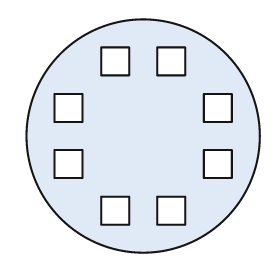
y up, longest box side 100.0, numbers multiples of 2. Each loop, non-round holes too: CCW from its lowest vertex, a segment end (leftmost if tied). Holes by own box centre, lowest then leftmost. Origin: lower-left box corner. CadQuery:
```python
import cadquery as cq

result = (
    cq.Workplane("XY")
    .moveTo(50.0, 50.0)
    .circle(50.0)
    .moveTo(32.0, 12.0)
    .lineTo(44.0, 12.0)
    .lineTo(44.0, 24.0)
    .lineTo(32.0, 24.0)
    .close()
    .moveTo(56.0, 12.0)
    .lineTo(68.0, 12.0)
    .lineTo(68.0, 24.0)
    .lineTo(56.0, 24.0)
    .close()
    .moveTo(12.0, 32.0)
    .lineTo(24.0, 32.0)
    .lineTo(24.0, 44.0)
    .lineTo(12.0, 44.0)
    .close()
    .moveTo(76.0, 32.0)
    .lineTo(88.0, 32.0)
    .lineTo(88.0, 44.0)
    .lineTo(76.0, 44.0)
    .close()
    .moveTo(12.0, 56.0)
    .lineTo(24.0, 56.0)
    .lineTo(24.0, 68.0)
    .lineTo(12.0, 68.0)
    .close()
    .moveTo(76.0, 56.0)
    .lineTo(88.0, 56.0)
    .lineTo(88.0, 68.0)
    .lineTo(76.0, 68.0)
    .close()
    .moveTo(32.0, 76.0)
    .lineTo(44.0, 76.0)
    .lineTo(44.0, 88.0)
    .lineTo(32.0, 88.0)
    .close()
    .moveTo(56.0, 76.0)
    .lineTo(68.0, 76.0)
    .lineTo(68.0, 88.0)
    .lineTo(56.0, 88.0)
    .close()
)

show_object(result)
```